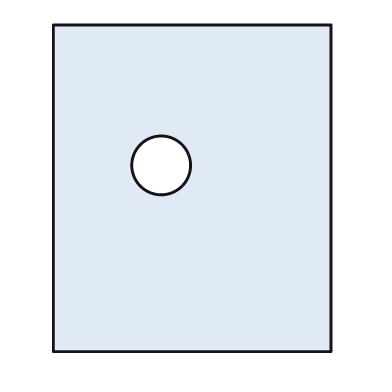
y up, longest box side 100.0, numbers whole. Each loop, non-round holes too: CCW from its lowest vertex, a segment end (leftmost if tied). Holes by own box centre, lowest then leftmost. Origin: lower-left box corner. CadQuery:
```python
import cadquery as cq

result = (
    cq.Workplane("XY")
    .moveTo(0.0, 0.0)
    .lineTo(85.0, 0.0)
    .lineTo(85.0, 100.0)
    .lineTo(0.0, 100.0)
    .close()
    .moveTo(33.0, 57.0)
    .circle(9.0)
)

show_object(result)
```